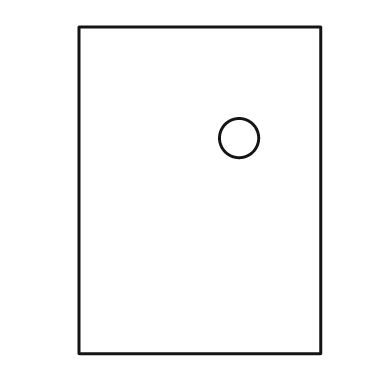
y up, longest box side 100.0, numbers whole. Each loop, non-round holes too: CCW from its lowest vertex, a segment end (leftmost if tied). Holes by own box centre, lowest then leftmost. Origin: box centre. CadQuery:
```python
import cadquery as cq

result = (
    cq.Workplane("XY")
    .moveTo(-37.0, -50.0)
    .lineTo(37.0, -50.0)
    .lineTo(37.0, 50.0)
    .lineTo(-37.0, 50.0)
    .close()
    .moveTo(12.0, 16.0)
    .circle(6.0)
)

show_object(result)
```